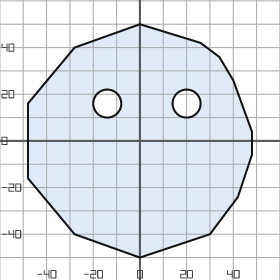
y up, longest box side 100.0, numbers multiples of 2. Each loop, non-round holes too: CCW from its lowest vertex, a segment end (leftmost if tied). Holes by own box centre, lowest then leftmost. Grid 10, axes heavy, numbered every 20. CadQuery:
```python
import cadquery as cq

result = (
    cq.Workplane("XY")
    .moveTo(0.0, -50.0)
    .lineTo(30.0, -40.0)
    .lineTo(42.0, -24.0)
    .lineTo(48.0, -6.0)
    .lineTo(48.0, 4.0)
    .lineTo(40.0, 26.0)
    .lineTo(34.0, 36.0)
    .lineTo(26.0, 42.0)
    .lineTo(0.0, 50.0)
    .lineTo(-28.0, 40.0)
    .lineTo(-48.0, 16.0)
    .lineTo(-48.0, -16.0)
    .lineTo(-28.0, -40.0)
    .close()
    .moveTo(-14.0, 16.0)
    .circle(6.0)
    .moveTo(20.0, 16.0)
    .circle(6.0)
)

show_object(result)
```